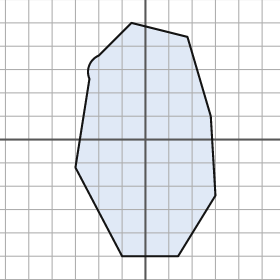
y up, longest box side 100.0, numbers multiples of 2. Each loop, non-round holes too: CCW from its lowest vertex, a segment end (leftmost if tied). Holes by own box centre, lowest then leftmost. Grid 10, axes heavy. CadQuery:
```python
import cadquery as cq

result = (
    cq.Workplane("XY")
    .moveTo(-10.0, -50.0)
    .lineTo(14.0, -50.0)
    .lineTo(30.0, -24.0)
    .lineTo(28.0, 10.0)
    .lineTo(18.0, 44.0)
    .lineTo(-6.0, 50.0)
    .lineTo(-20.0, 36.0)
    .threePointArc((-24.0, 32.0), (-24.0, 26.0))
    .lineTo(-30.0, -12.0)
    .close()
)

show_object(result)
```